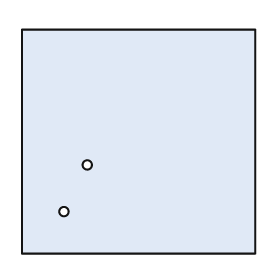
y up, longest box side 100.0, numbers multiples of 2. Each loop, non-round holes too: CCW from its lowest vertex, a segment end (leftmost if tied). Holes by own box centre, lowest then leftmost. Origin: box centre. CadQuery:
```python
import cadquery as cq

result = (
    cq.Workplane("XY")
    .moveTo(-50.0, -48.0)
    .lineTo(50.0, -48.0)
    .lineTo(50.0, 48.0)
    .lineTo(-50.0, 48.0)
    .close()
    .moveTo(-32.0, -30.0)
    .circle(2.0)
    .moveTo(-22.0, -10.0)
    .circle(2.0)
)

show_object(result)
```